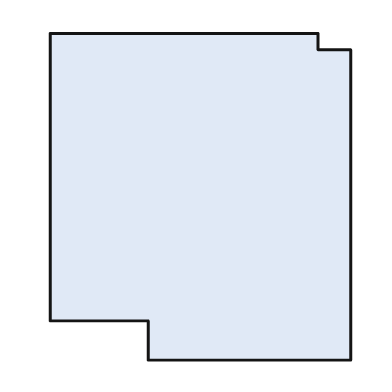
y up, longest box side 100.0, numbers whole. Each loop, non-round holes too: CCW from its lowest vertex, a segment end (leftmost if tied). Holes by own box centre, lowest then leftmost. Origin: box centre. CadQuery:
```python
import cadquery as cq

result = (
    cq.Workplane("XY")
    .moveTo(-16.0, -50.0)
    .lineTo(46.0, -50.0)
    .lineTo(46.0, 45.0)
    .lineTo(36.0, 45.0)
    .lineTo(36.0, 50.0)
    .lineTo(-46.0, 50.0)
    .lineTo(-46.0, -38.0)
    .lineTo(-16.0, -38.0)
    .close()
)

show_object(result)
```